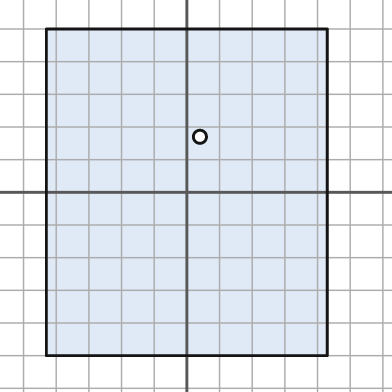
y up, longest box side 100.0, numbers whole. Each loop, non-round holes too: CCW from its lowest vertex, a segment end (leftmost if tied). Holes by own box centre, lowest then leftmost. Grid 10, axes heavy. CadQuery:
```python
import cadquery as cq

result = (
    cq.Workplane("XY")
    .moveTo(-43.0, -50.0)
    .lineTo(43.0, -50.0)
    .lineTo(43.0, 50.0)
    .lineTo(-43.0, 50.0)
    .close()
    .moveTo(4.0, 17.0)
    .circle(2.0)
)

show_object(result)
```